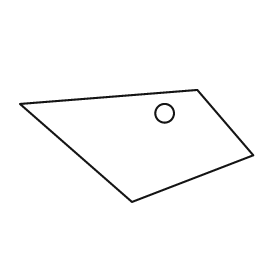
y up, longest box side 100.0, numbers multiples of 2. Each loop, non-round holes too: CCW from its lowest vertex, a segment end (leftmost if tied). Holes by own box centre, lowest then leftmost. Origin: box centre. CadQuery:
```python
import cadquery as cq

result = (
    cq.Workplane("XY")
    .moveTo(-2.0, -24.0)
    .lineTo(50.0, -4.0)
    .lineTo(26.0, 24.0)
    .lineTo(-50.0, 18.0)
    .close()
    .moveTo(12.0, 14.0)
    .circle(4.0)
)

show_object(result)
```